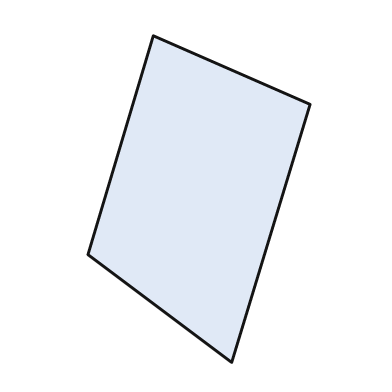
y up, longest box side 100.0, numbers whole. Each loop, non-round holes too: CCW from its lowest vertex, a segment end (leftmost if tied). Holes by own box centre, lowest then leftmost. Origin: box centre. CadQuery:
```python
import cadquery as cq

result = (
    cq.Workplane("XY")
    .moveTo(10.0, -50.0)
    .lineTo(34.0, 29.0)
    .lineTo(-14.0, 50.0)
    .lineTo(-34.0, -17.0)
    .close()
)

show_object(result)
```